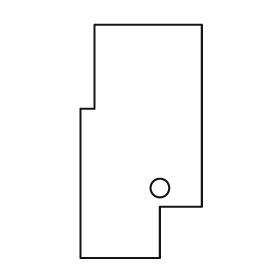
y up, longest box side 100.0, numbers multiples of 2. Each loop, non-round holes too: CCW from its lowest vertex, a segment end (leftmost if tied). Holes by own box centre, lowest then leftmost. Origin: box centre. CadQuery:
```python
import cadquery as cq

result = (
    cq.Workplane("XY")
    .moveTo(-26.0, -50.0)
    .lineTo(8.0, -50.0)
    .lineTo(8.0, -28.0)
    .lineTo(26.0, -28.0)
    .lineTo(26.0, 50.0)
    .lineTo(-20.0, 50.0)
    .lineTo(-20.0, 14.0)
    .lineTo(-26.0, 14.0)
    .close()
    .moveTo(8.0, -20.0)
    .circle(4.0)
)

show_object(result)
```